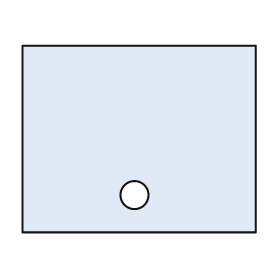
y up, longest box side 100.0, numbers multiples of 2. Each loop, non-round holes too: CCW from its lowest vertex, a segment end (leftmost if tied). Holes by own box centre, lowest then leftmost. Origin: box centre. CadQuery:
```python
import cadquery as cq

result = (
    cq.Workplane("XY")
    .moveTo(-50.0, -40.0)
    .lineTo(50.0, -40.0)
    .lineTo(50.0, 40.0)
    .lineTo(-50.0, 40.0)
    .close()
    .moveTo(-2.0, -24.0)
    .circle(6.0)
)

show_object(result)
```